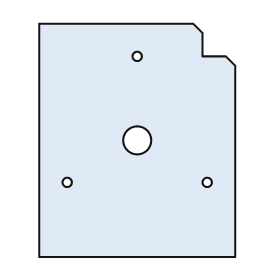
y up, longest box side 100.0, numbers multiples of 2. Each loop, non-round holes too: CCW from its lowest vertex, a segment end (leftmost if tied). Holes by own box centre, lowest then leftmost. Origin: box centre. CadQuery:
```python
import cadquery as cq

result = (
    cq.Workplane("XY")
    .moveTo(-42.0, -50.0)
    .lineTo(42.0, -50.0)
    .lineTo(42.0, 32.0)
    .lineTo(38.0, 36.0)
    .lineTo(28.0, 36.0)
    .lineTo(28.0, 46.0)
    .lineTo(24.0, 50.0)
    .lineTo(-42.0, 50.0)
    .close()
    .moveTo(-30.0, -18.0)
    .circle(2.0)
    .moveTo(30.0, -18.0)
    .circle(2.0)
    .moveTo(0.0, 0.0)
    .circle(6.0)
    .moveTo(0.0, 36.0)
    .circle(2.0)
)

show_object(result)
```